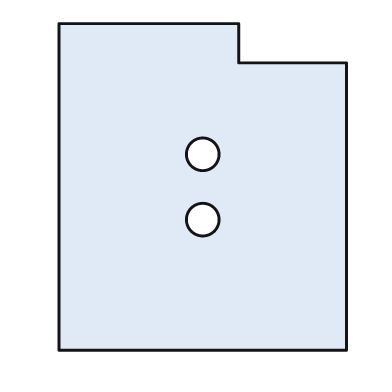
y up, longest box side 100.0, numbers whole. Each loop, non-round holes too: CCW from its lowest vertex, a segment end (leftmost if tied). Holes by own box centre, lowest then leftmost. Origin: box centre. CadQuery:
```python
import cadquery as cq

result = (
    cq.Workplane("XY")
    .moveTo(-44.0, -50.0)
    .lineTo(44.0, -50.0)
    .lineTo(44.0, 38.0)
    .lineTo(11.0, 38.0)
    .lineTo(11.0, 50.0)
    .lineTo(-44.0, 50.0)
    .close()
    .moveTo(0.0, -10.0)
    .circle(5.0)
    .moveTo(0.0, 10.0)
    .circle(5.0)
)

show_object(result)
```